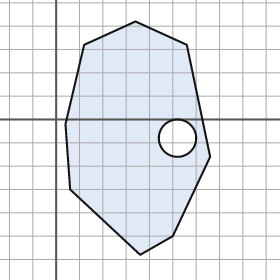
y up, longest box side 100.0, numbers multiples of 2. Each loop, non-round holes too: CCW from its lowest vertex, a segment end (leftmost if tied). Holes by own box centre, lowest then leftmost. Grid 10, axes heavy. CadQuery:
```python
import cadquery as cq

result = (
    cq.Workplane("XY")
    .moveTo(36.0, -58.0)
    .lineTo(50.0, -50.0)
    .lineTo(66.0, -16.0)
    .lineTo(56.0, 32.0)
    .lineTo(34.0, 42.0)
    .lineTo(12.0, 32.0)
    .lineTo(4.0, -2.0)
    .lineTo(6.0, -30.0)
    .close()
    .moveTo(52.0, -8.0)
    .circle(8.0)
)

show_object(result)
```